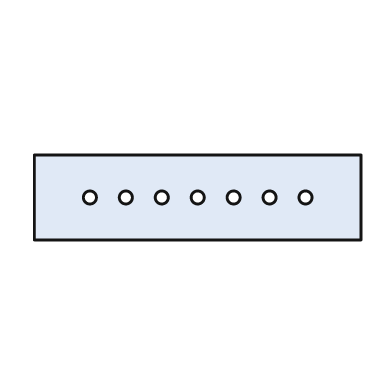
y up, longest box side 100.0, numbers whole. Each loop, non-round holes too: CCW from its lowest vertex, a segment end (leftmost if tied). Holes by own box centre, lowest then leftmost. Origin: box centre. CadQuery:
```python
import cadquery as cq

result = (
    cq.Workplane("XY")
    .moveTo(-50.0, -13.0)
    .lineTo(50.0, -13.0)
    .lineTo(50.0, 13.0)
    .lineTo(-50.0, 13.0)
    .close()
    .moveTo(-33.0, 0.0)
    .circle(2.0)
    .moveTo(-22.0, 0.0)
    .circle(2.0)
    .moveTo(-11.0, 0.0)
    .circle(2.0)
    .moveTo(0.0, 0.0)
    .circle(2.0)
    .moveTo(11.0, 0.0)
    .circle(2.0)
    .moveTo(22.0, 0.0)
    .circle(2.0)
    .moveTo(33.0, 0.0)
    .circle(2.0)
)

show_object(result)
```